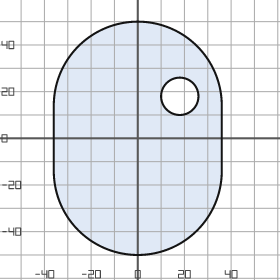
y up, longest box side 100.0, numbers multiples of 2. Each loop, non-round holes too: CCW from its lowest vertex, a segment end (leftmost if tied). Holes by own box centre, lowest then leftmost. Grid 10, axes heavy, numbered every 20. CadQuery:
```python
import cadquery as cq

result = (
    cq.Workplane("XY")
    .moveTo(-36.0, -14.0)
    .threePointArc((0.0, -50.0), (36.0, -14.0))
    .lineTo(36.0, 14.0)
    .threePointArc((0.0, 50.0), (-36.0, 14.0))
    .close()
    .moveTo(18.0, 18.0)
    .circle(8.0)
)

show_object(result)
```